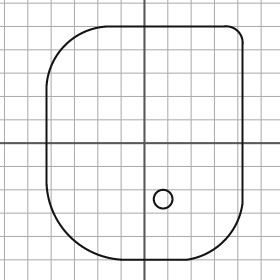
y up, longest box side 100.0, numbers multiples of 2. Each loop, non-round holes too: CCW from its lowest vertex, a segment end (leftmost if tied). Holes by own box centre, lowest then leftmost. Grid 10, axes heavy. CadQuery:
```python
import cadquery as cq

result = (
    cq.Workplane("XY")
    .moveTo(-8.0, -50.0)
    .lineTo(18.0, -50.0)
    .threePointArc((34.0, -42.0), (42.0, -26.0))
    .lineTo(42.0, 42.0)
    .threePointArc((40.0, 48.0), (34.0, 50.0))
    .lineTo(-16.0, 50.0)
    .threePointArc((-34.0, 42.0), (-42.0, 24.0))
    .lineTo(-42.0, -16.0)
    .threePointArc((-32.0, -40.0), (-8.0, -50.0))
    .close()
    .moveTo(8.0, -24.0)
    .circle(4.0)
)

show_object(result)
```